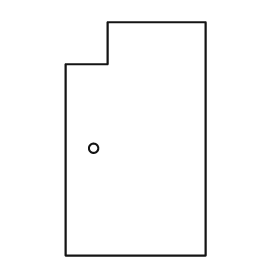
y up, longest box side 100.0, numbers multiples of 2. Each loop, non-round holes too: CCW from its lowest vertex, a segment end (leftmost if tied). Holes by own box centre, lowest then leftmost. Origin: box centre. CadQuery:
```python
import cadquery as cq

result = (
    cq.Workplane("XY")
    .moveTo(-30.0, -50.0)
    .lineTo(30.0, -50.0)
    .lineTo(30.0, 50.0)
    .lineTo(-12.0, 50.0)
    .lineTo(-12.0, 32.0)
    .lineTo(-30.0, 32.0)
    .close()
    .moveTo(-18.0, -4.0)
    .circle(2.0)
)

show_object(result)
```